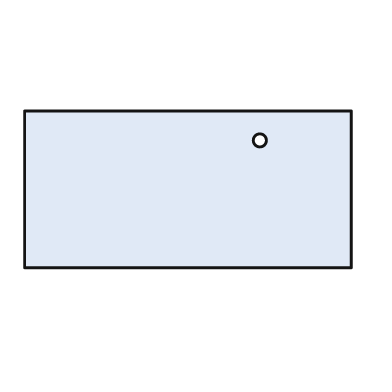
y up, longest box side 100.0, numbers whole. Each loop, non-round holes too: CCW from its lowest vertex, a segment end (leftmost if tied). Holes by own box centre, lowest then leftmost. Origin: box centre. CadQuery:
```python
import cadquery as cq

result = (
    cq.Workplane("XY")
    .moveTo(-50.0, -24.0)
    .lineTo(50.0, -24.0)
    .lineTo(50.0, 24.0)
    .lineTo(-50.0, 24.0)
    .close()
    .moveTo(22.0, 15.0)
    .circle(2.0)
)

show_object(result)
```